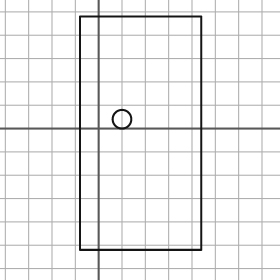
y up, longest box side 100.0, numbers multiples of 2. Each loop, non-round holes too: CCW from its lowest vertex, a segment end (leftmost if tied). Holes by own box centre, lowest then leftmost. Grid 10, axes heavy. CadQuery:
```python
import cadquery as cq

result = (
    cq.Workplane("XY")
    .moveTo(-8.0, -52.0)
    .lineTo(44.0, -52.0)
    .lineTo(44.0, 48.0)
    .lineTo(-8.0, 48.0)
    .close()
    .moveTo(10.0, 4.0)
    .circle(4.0)
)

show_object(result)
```